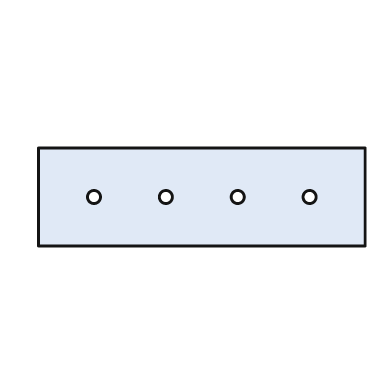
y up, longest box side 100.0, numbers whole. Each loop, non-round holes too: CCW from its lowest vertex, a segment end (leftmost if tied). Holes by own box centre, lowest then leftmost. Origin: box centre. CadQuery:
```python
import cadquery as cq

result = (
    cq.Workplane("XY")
    .moveTo(-50.0, -15.0)
    .lineTo(50.0, -15.0)
    .lineTo(50.0, 15.0)
    .lineTo(-50.0, 15.0)
    .close()
    .moveTo(-33.0, 0.0)
    .circle(2.0)
    .moveTo(-11.0, 0.0)
    .circle(2.0)
    .moveTo(11.0, 0.0)
    .circle(2.0)
    .moveTo(33.0, 0.0)
    .circle(2.0)
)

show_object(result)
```